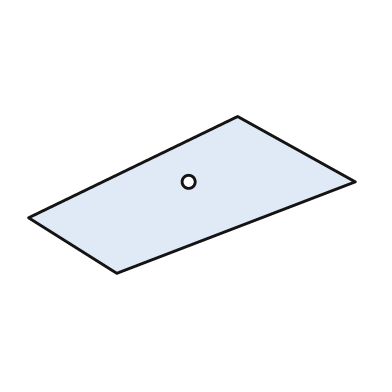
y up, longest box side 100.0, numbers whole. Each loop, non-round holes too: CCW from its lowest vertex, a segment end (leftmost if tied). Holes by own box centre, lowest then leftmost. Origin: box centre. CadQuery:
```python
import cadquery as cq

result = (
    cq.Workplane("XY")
    .moveTo(-23.0, -24.0)
    .lineTo(50.0, 4.0)
    .lineTo(14.0, 24.0)
    .lineTo(-50.0, -7.0)
    .close()
    .moveTo(-1.0, 4.0)
    .circle(2.0)
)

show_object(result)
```